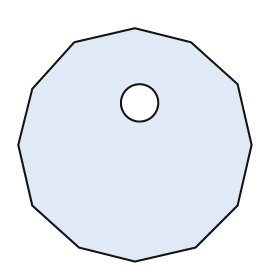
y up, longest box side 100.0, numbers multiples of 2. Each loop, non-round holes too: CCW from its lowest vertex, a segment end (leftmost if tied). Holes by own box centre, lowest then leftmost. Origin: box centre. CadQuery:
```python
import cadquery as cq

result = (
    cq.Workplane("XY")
    .moveTo(0.0, -50.0)
    .lineTo(26.0, -44.0)
    .lineTo(44.0, -26.0)
    .lineTo(50.0, 0.0)
    .lineTo(44.0, 26.0)
    .lineTo(24.0, 44.0)
    .lineTo(0.0, 50.0)
    .lineTo(-26.0, 44.0)
    .lineTo(-44.0, 24.0)
    .lineTo(-50.0, 0.0)
    .lineTo(-44.0, -26.0)
    .lineTo(-24.0, -44.0)
    .close()
    .moveTo(2.0, 18.0)
    .circle(8.0)
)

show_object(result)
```